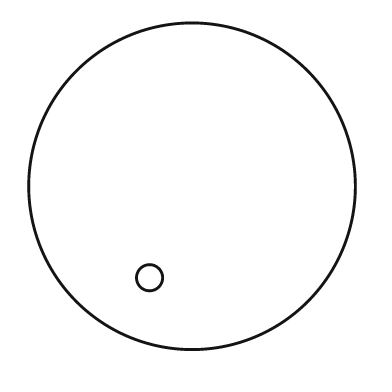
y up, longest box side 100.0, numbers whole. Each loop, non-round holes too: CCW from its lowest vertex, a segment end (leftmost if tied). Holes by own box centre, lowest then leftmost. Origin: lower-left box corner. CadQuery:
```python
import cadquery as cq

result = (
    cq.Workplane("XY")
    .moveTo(50.0, 50.0)
    .circle(50.0)
    .moveTo(37.0, 22.0)
    .circle(4.0)
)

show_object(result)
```